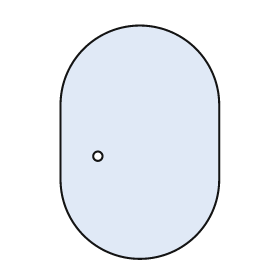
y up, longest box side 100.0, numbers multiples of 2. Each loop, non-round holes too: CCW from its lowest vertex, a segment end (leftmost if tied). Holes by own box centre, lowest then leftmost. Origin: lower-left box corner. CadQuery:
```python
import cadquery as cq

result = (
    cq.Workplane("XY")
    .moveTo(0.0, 34.0)
    .threePointArc((34.0, 0.0), (68.0, 34.0))
    .lineTo(68.0, 66.0)
    .threePointArc((34.0, 100.0), (0.0, 66.0))
    .close()
    .moveTo(16.0, 44.0)
    .circle(2.0)
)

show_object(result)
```